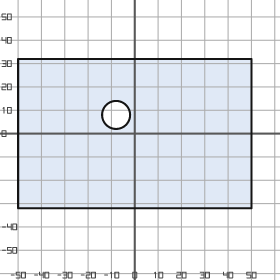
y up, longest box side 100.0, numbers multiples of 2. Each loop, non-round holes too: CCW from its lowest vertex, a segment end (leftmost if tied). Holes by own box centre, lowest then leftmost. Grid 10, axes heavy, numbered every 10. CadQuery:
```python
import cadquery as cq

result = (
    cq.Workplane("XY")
    .moveTo(-50.0, -32.0)
    .lineTo(50.0, -32.0)
    .lineTo(50.0, 32.0)
    .lineTo(-50.0, 32.0)
    .close()
    .moveTo(-8.0, 8.0)
    .circle(6.0)
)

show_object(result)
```